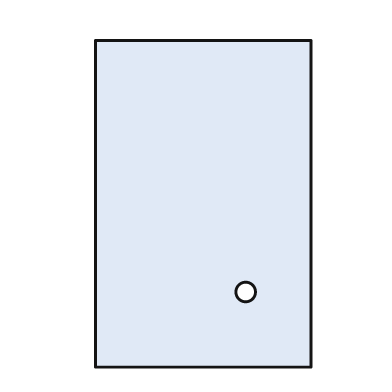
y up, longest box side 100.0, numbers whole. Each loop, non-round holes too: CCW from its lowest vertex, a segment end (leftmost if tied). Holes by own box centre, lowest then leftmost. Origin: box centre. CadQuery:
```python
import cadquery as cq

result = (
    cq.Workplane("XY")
    .moveTo(-33.0, -50.0)
    .lineTo(33.0, -50.0)
    .lineTo(33.0, 50.0)
    .lineTo(-33.0, 50.0)
    .close()
    .moveTo(13.0, -27.0)
    .circle(3.0)
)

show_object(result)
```